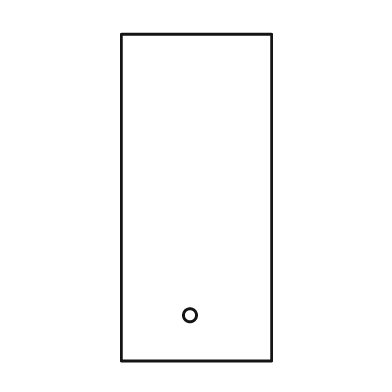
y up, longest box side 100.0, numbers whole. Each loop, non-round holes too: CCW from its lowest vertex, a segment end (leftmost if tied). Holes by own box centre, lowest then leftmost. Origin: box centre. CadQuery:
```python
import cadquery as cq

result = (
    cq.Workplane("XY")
    .moveTo(-23.0, -50.0)
    .lineTo(23.0, -50.0)
    .lineTo(23.0, 50.0)
    .lineTo(-23.0, 50.0)
    .close()
    .moveTo(-2.0, -36.0)
    .circle(2.0)
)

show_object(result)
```